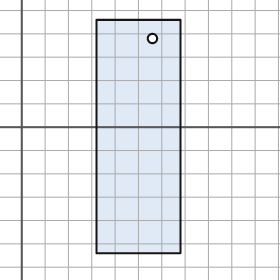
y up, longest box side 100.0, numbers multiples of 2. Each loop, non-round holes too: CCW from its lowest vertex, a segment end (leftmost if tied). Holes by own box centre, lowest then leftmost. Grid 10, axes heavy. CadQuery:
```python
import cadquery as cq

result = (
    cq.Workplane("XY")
    .moveTo(32.0, -54.0)
    .lineTo(68.0, -54.0)
    .lineTo(68.0, 46.0)
    .lineTo(32.0, 46.0)
    .close()
    .moveTo(56.0, 38.0)
    .circle(2.0)
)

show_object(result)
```